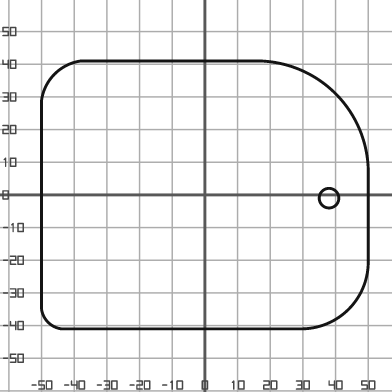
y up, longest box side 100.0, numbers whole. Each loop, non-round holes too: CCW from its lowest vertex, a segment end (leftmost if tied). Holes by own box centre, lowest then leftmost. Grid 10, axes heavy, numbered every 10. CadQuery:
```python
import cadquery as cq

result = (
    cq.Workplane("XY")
    .moveTo(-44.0, -41.0)
    .lineTo(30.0, -41.0)
    .threePointArc((44.0, -35.0), (50.0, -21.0))
    .lineTo(50.0, 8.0)
    .threePointArc((40.0, 31.0), (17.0, 41.0))
    .lineTo(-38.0, 41.0)
    .threePointArc((-46.0, 37.0), (-50.0, 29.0))
    .lineTo(-50.0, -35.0)
    .threePointArc((-48.0, -39.0), (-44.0, -41.0))
    .close()
    .moveTo(38.0, -1.0)
    .circle(3.0)
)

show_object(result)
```